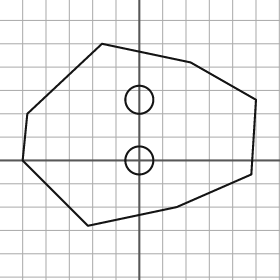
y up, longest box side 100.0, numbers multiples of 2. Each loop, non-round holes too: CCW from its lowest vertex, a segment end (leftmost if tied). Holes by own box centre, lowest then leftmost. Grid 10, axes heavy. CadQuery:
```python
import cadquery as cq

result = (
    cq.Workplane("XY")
    .moveTo(-22.0, -28.0)
    .lineTo(16.0, -20.0)
    .lineTo(48.0, -6.0)
    .lineTo(50.0, 26.0)
    .lineTo(22.0, 42.0)
    .lineTo(-16.0, 50.0)
    .lineTo(-48.0, 20.0)
    .lineTo(-50.0, 0.0)
    .close()
    .moveTo(0.0, 0.0)
    .circle(6.0)
    .moveTo(0.0, 26.0)
    .circle(6.0)
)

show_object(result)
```